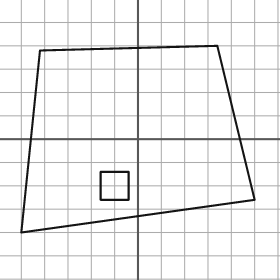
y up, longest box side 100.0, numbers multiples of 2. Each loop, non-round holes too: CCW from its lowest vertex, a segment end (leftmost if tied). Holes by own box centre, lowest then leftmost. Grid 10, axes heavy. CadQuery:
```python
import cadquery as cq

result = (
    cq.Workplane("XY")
    .moveTo(-50.0, -40.0)
    .lineTo(50.0, -26.0)
    .lineTo(34.0, 40.0)
    .lineTo(-42.0, 38.0)
    .close()
    .moveTo(-16.0, -26.0)
    .lineTo(-4.0, -26.0)
    .lineTo(-4.0, -14.0)
    .lineTo(-16.0, -14.0)
    .close()
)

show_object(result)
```